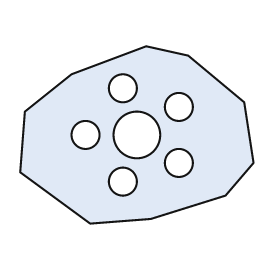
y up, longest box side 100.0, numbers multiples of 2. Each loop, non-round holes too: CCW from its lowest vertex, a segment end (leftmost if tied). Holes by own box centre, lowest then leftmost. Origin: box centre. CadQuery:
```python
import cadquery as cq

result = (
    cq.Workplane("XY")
    .moveTo(-20.0, -38.0)
    .lineTo(6.0, -36.0)
    .lineTo(38.0, -26.0)
    .lineTo(50.0, -12.0)
    .lineTo(46.0, 14.0)
    .lineTo(22.0, 34.0)
    .lineTo(4.0, 38.0)
    .lineTo(-28.0, 26.0)
    .lineTo(-48.0, 10.0)
    .lineTo(-50.0, -16.0)
    .close()
    .moveTo(-6.0, -20.0)
    .circle(6.0)
    .moveTo(18.0, -12.0)
    .circle(6.0)
    .moveTo(-22.0, 0.0)
    .circle(6.0)
    .moveTo(0.0, 0.0)
    .circle(10.0)
    .moveTo(18.0, 12.0)
    .circle(6.0)
    .moveTo(-6.0, 20.0)
    .circle(6.0)
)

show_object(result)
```